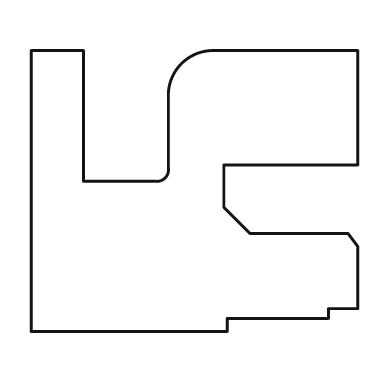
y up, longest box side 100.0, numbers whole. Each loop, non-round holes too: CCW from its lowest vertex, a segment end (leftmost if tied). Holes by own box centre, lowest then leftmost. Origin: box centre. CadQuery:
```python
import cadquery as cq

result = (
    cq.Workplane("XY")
    .moveTo(-50.0, -43.0)
    .lineTo(10.0, -43.0)
    .lineTo(10.0, -39.0)
    .lineTo(41.0, -39.0)
    .lineTo(41.0, -36.0)
    .lineTo(50.0, -36.0)
    .lineTo(50.0, -17.0)
    .lineTo(47.0, -13.0)
    .lineTo(17.0, -13.0)
    .lineTo(9.0, -5.0)
    .lineTo(9.0, 8.0)
    .lineTo(50.0, 8.0)
    .lineTo(50.0, 43.0)
    .lineTo(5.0, 43.0)
    .threePointArc((-4.0, 39.0), (-8.0, 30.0))
    .lineTo(-8.0, 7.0)
    .threePointArc((-9.0, 4.0), (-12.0, 3.0))
    .lineTo(-34.0, 3.0)
    .lineTo(-34.0, 43.0)
    .lineTo(-50.0, 43.0)
    .close()
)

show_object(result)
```